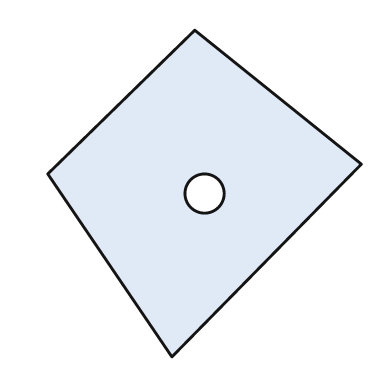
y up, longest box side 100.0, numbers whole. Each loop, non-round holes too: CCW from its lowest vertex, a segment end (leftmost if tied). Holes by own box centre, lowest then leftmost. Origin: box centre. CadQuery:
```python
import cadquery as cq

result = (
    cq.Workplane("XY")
    .moveTo(-10.0, -50.0)
    .lineTo(48.0, 9.0)
    .lineTo(-3.0, 50.0)
    .lineTo(-48.0, 6.0)
    .close()
    .moveTo(0.0, 0.0)
    .circle(6.0)
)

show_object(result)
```